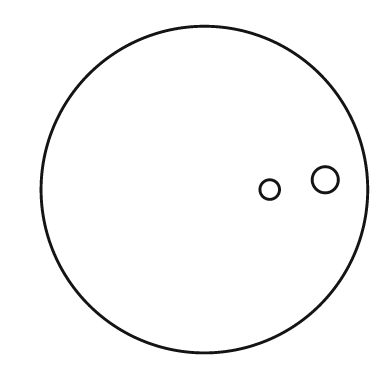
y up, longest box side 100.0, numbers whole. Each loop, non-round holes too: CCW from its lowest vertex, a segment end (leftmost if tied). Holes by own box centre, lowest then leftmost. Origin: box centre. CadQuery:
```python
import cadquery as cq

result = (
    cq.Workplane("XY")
    .moveTo(0.0, 0.0)
    .circle(50.0)
    .moveTo(20.0, 0.0)
    .circle(3.0)
    .moveTo(37.0, 3.0)
    .circle(4.0)
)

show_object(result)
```